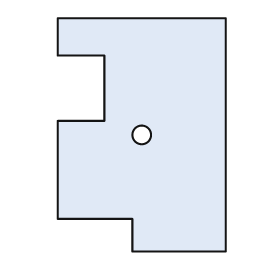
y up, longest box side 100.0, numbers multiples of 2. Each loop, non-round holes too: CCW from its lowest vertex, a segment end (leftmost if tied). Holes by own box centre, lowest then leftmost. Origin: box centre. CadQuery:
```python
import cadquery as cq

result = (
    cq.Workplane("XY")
    .moveTo(-4.0, -50.0)
    .lineTo(36.0, -50.0)
    .lineTo(36.0, 50.0)
    .lineTo(-36.0, 50.0)
    .lineTo(-36.0, 34.0)
    .lineTo(-16.0, 34.0)
    .lineTo(-16.0, 6.0)
    .lineTo(-36.0, 6.0)
    .lineTo(-36.0, -36.0)
    .lineTo(-4.0, -36.0)
    .close()
    .moveTo(0.0, 0.0)
    .circle(4.0)
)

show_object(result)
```